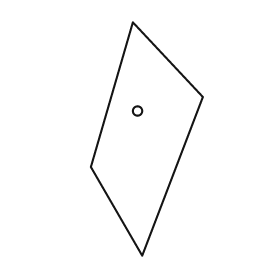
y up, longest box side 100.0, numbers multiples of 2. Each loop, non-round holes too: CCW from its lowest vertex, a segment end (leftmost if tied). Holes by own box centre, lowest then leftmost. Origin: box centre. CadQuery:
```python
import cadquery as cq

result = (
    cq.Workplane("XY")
    .moveTo(-2.0, -50.0)
    .lineTo(24.0, 18.0)
    .lineTo(-6.0, 50.0)
    .lineTo(-24.0, -12.0)
    .close()
    .moveTo(-4.0, 12.0)
    .circle(2.0)
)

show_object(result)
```